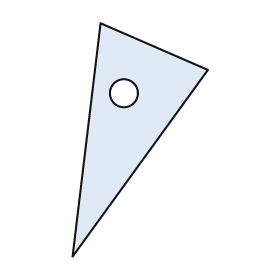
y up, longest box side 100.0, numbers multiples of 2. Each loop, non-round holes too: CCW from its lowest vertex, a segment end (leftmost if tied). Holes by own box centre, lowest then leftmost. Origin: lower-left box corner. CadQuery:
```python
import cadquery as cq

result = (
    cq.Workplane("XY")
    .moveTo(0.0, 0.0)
    .lineTo(58.0, 80.0)
    .lineTo(12.0, 100.0)
    .close()
    .moveTo(22.0, 70.0)
    .circle(6.0)
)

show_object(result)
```